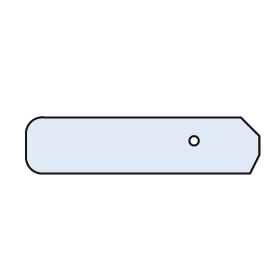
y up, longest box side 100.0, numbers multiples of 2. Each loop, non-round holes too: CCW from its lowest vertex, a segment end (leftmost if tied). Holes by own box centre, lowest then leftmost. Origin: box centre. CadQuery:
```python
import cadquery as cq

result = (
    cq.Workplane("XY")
    .moveTo(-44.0, -12.0)
    .lineTo(46.0, -12.0)
    .lineTo(50.0, -4.0)
    .lineTo(50.0, 4.0)
    .lineTo(42.0, 12.0)
    .lineTo(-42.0, 12.0)
    .threePointArc((-48.0, 10.0), (-50.0, 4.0))
    .lineTo(-50.0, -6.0)
    .threePointArc((-48.0, -10.0), (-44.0, -12.0))
    .close()
    .moveTo(22.0, 2.0)
    .circle(2.0)
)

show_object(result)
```